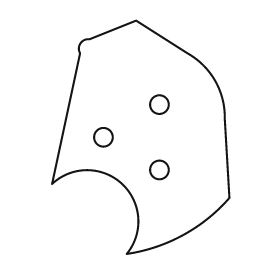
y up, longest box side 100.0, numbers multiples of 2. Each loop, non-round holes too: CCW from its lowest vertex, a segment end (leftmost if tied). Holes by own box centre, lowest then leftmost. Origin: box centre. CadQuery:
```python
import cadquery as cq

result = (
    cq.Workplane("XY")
    .moveTo(-6.0, -50.0)
    .threePointArc((18.0, -42.0), (38.0, -26.0))
    .lineTo(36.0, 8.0)
    .threePointArc((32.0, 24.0), (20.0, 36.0))
    .lineTo(-2.0, 50.0)
    .lineTo(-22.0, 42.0)
    .threePointArc((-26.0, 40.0), (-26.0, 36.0))
    .lineTo(-38.0, -20.0)
    .threePointArc((-8.0, -20.0), (-6.0, -50.0))
    .close()
    .moveTo(8.0, -14.0)
    .circle(4.0)
    .moveTo(-16.0, 0.0)
    .circle(4.0)
    .moveTo(8.0, 14.0)
    .circle(4.0)
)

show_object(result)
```